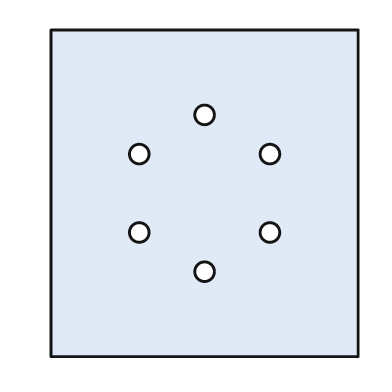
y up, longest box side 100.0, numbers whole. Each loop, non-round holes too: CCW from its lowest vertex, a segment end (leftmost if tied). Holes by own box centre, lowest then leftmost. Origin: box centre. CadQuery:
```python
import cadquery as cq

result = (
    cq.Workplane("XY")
    .moveTo(-47.0, -50.0)
    .lineTo(47.0, -50.0)
    .lineTo(47.0, 50.0)
    .lineTo(-47.0, 50.0)
    .close()
    .moveTo(0.0, -24.0)
    .circle(3.0)
    .moveTo(-20.0, -12.0)
    .circle(3.0)
    .moveTo(20.0, -12.0)
    .circle(3.0)
    .moveTo(-20.0, 12.0)
    .circle(3.0)
    .moveTo(20.0, 12.0)
    .circle(3.0)
    .moveTo(0.0, 24.0)
    .circle(3.0)
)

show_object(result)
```